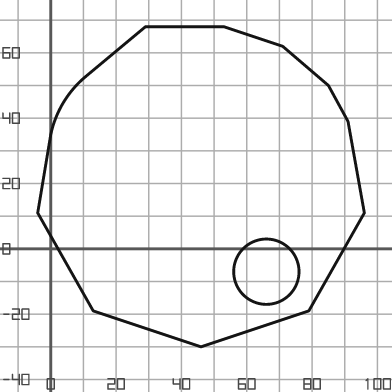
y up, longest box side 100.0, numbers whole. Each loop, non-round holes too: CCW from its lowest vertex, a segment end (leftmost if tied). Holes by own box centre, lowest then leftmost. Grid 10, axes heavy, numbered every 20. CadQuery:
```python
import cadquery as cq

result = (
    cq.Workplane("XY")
    .moveTo(46.0, -30.0)
    .lineTo(79.0, -19.0)
    .lineTo(96.0, 11.0)
    .lineTo(91.0, 39.0)
    .lineTo(85.0, 50.0)
    .lineTo(71.0, 62.0)
    .lineTo(53.0, 68.0)
    .lineTo(29.0, 68.0)
    .lineTo(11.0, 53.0)
    .threePointArc((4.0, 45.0), (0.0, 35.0))
    .lineTo(-4.0, 11.0)
    .lineTo(13.0, -19.0)
    .close()
    .moveTo(66.0, -7.0)
    .circle(10.0)
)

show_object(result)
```